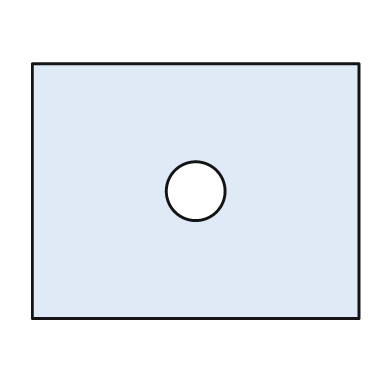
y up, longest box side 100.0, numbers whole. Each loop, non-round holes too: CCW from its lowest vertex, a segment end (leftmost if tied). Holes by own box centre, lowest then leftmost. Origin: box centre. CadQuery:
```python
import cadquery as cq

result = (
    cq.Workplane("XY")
    .moveTo(-50.0, -39.0)
    .lineTo(50.0, -39.0)
    .lineTo(50.0, 39.0)
    .lineTo(-50.0, 39.0)
    .close()
    .moveTo(0.0, 0.0)
    .circle(9.0)
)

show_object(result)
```